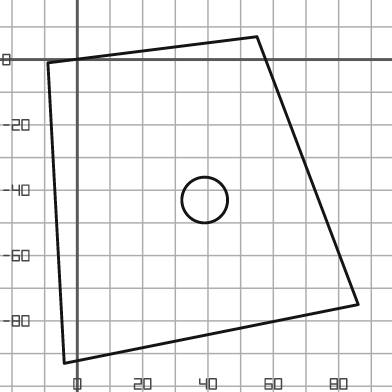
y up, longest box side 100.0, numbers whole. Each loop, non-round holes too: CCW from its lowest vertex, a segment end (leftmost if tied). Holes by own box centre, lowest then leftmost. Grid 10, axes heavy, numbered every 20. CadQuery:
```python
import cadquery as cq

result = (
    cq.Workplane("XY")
    .moveTo(-4.0, -93.0)
    .lineTo(86.0, -75.0)
    .lineTo(55.0, 7.0)
    .lineTo(-9.0, -1.0)
    .close()
    .moveTo(39.0, -43.0)
    .circle(7.0)
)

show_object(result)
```